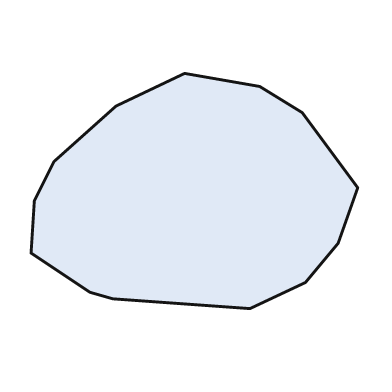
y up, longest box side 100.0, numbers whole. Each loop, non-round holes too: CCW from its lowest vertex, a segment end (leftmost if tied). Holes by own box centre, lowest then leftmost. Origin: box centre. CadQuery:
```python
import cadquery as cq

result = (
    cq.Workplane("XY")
    .moveTo(17.0, -36.0)
    .lineTo(34.0, -28.0)
    .lineTo(44.0, -16.0)
    .lineTo(50.0, 1.0)
    .lineTo(33.0, 24.0)
    .lineTo(20.0, 32.0)
    .lineTo(-3.0, 36.0)
    .lineTo(-24.0, 26.0)
    .lineTo(-43.0, 9.0)
    .lineTo(-49.0, -3.0)
    .lineTo(-50.0, -19.0)
    .lineTo(-32.0, -31.0)
    .lineTo(-25.0, -33.0)
    .close()
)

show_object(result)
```